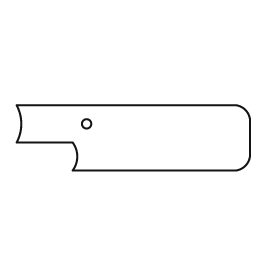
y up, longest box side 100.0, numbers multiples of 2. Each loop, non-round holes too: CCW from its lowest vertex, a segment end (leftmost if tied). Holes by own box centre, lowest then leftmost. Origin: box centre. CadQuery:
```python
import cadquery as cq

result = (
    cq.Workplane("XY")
    .moveTo(-26.0, -14.0)
    .lineTo(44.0, -14.0)
    .threePointArc((48.0, -12.0), (50.0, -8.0))
    .lineTo(50.0, 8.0)
    .threePointArc((48.0, 12.0), (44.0, 14.0))
    .lineTo(-50.0, 14.0)
    .threePointArc((-48.0, 6.0), (-50.0, -2.0))
    .lineTo(-26.0, -2.0)
    .threePointArc((-24.0, -8.0), (-26.0, -14.0))
    .close()
    .moveTo(-20.0, 6.0)
    .circle(2.0)
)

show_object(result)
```